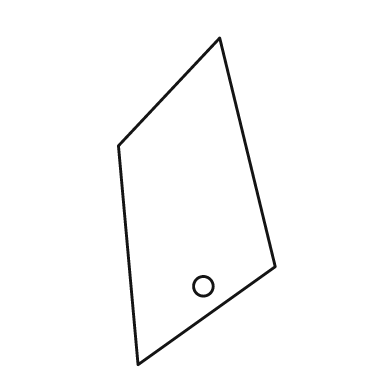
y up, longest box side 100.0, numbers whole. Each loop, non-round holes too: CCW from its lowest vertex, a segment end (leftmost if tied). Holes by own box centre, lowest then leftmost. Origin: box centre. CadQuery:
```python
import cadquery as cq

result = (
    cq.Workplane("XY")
    .moveTo(-18.0, -50.0)
    .lineTo(24.0, -20.0)
    .lineTo(7.0, 50.0)
    .lineTo(-24.0, 17.0)
    .close()
    .moveTo(2.0, -26.0)
    .circle(3.0)
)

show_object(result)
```